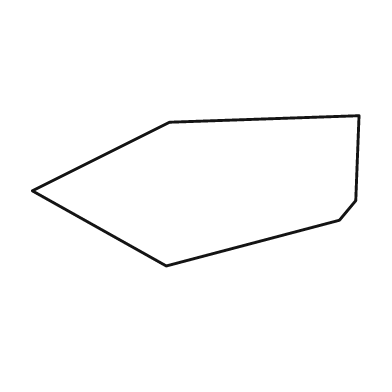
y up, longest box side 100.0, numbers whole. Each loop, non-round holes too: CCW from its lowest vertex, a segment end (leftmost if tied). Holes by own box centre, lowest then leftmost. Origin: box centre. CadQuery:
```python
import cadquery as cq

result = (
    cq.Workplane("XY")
    .moveTo(-9.0, -23.0)
    .lineTo(44.0, -9.0)
    .lineTo(49.0, -3.0)
    .lineTo(50.0, 23.0)
    .lineTo(-8.0, 21.0)
    .lineTo(-50.0, 0.0)
    .close()
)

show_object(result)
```